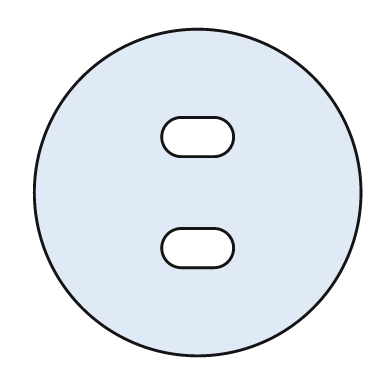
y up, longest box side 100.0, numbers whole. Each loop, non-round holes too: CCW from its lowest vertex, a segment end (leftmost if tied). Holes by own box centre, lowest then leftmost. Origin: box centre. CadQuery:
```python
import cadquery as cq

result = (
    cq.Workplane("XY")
    .moveTo(0.0, 0.0)
    .circle(50.0)
    .moveTo(-5.0, -23.0)
    .lineTo(5.0, -23.0)
    .threePointArc((11.0, -17.0), (5.0, -11.0))
    .lineTo(-5.0, -11.0)
    .threePointArc((-11.0, -17.0), (-5.0, -23.0))
    .close()
    .moveTo(-5.0, 11.0)
    .lineTo(5.0, 11.0)
    .threePointArc((11.0, 17.0), (5.0, 23.0))
    .lineTo(-5.0, 23.0)
    .threePointArc((-11.0, 17.0), (-5.0, 11.0))
    .close()
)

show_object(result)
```